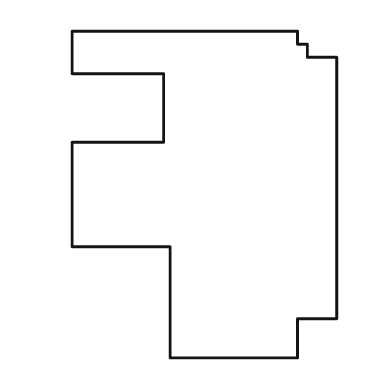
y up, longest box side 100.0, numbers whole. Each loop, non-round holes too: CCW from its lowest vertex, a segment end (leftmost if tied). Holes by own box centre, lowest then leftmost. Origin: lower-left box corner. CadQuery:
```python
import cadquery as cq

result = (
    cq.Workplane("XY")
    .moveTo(30.0, 0.0)
    .lineTo(69.0, 0.0)
    .lineTo(69.0, 12.0)
    .lineTo(81.0, 12.0)
    .lineTo(81.0, 92.0)
    .lineTo(72.0, 92.0)
    .lineTo(72.0, 96.0)
    .lineTo(69.0, 96.0)
    .lineTo(69.0, 100.0)
    .lineTo(0.0, 100.0)
    .lineTo(0.0, 87.0)
    .lineTo(28.0, 87.0)
    .lineTo(28.0, 66.0)
    .lineTo(0.0, 66.0)
    .lineTo(0.0, 34.0)
    .lineTo(30.0, 34.0)
    .close()
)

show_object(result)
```